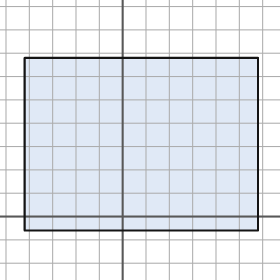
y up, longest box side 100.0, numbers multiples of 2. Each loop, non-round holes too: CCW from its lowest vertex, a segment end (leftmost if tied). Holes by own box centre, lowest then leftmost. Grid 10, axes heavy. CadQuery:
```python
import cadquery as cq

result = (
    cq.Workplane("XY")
    .moveTo(-42.0, -6.0)
    .lineTo(58.0, -6.0)
    .lineTo(58.0, 68.0)
    .lineTo(-42.0, 68.0)
    .close()
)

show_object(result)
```